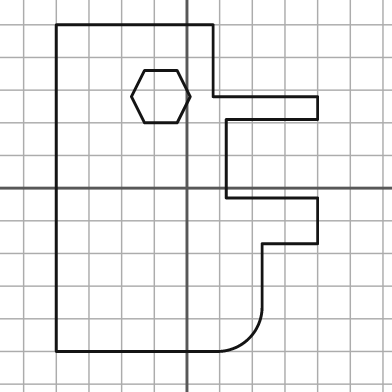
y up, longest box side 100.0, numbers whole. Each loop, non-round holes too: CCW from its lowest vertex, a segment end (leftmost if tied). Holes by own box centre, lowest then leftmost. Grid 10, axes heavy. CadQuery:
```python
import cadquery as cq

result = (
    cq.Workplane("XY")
    .moveTo(-40.0, -50.0)
    .lineTo(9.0, -50.0)
    .threePointArc((19.0, -46.0), (23.0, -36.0))
    .lineTo(23.0, -17.0)
    .lineTo(40.0, -17.0)
    .lineTo(40.0, -3.0)
    .lineTo(12.0, -3.0)
    .lineTo(12.0, 21.0)
    .lineTo(40.0, 21.0)
    .lineTo(40.0, 28.0)
    .lineTo(8.0, 28.0)
    .lineTo(8.0, 50.0)
    .lineTo(-40.0, 50.0)
    .close()
    .moveTo(-13.0, 20.0)
    .lineTo(-3.0, 20.0)
    .lineTo(1.0, 28.0)
    .lineTo(-3.0, 36.0)
    .lineTo(-13.0, 36.0)
    .lineTo(-17.0, 28.0)
    .close()
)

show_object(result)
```